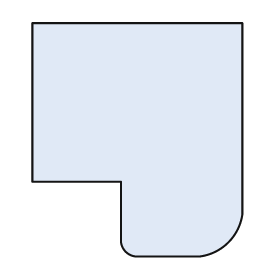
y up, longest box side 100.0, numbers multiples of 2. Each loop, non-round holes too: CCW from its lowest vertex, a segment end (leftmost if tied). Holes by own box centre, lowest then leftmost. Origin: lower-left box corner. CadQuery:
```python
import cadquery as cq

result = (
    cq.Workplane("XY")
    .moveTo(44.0, 0.0)
    .lineTo(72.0, 0.0)
    .threePointArc((84.0, 6.0), (90.0, 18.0))
    .lineTo(90.0, 100.0)
    .lineTo(0.0, 100.0)
    .lineTo(0.0, 32.0)
    .lineTo(38.0, 32.0)
    .lineTo(38.0, 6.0)
    .threePointArc((40.0, 2.0), (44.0, 0.0))
    .close()
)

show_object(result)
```